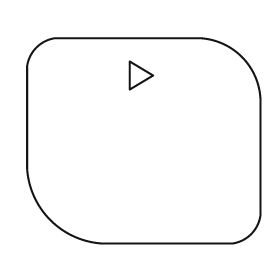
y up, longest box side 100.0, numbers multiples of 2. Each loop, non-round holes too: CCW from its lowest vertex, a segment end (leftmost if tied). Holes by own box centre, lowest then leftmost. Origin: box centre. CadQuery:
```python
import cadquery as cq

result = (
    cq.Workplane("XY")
    .moveTo(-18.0, -44.0)
    .lineTo(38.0, -44.0)
    .threePointArc((46.0, -40.0), (50.0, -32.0))
    .lineTo(50.0, 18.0)
    .threePointArc((42.0, 36.0), (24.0, 44.0))
    .lineTo(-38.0, 44.0)
    .threePointArc((-46.0, 40.0), (-50.0, 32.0))
    .lineTo(-50.0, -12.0)
    .threePointArc((-40.0, -34.0), (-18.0, -44.0))
    .close()
    .moveTo(-6.0, 22.0)
    .lineTo(4.0, 28.0)
    .lineTo(-6.0, 34.0)
    .close()
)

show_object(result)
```